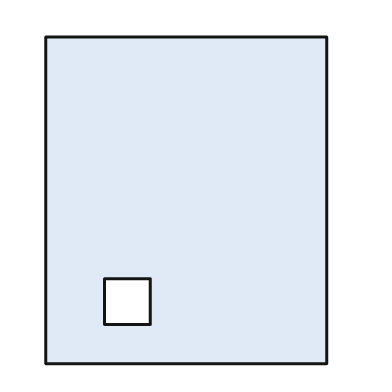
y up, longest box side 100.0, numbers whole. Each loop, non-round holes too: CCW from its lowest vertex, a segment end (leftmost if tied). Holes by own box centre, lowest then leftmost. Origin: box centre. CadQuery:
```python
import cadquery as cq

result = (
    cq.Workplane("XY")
    .moveTo(-43.0, -50.0)
    .lineTo(43.0, -50.0)
    .lineTo(43.0, 50.0)
    .lineTo(-43.0, 50.0)
    .close()
    .moveTo(-25.0, -38.0)
    .lineTo(-11.0, -38.0)
    .lineTo(-11.0, -24.0)
    .lineTo(-25.0, -24.0)
    .close()
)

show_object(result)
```